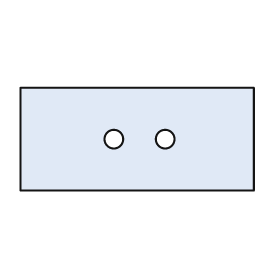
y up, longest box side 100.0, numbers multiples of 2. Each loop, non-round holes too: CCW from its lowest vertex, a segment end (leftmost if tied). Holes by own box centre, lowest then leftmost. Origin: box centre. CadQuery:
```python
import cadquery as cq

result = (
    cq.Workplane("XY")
    .moveTo(-50.0, -22.0)
    .lineTo(50.0, -22.0)
    .lineTo(50.0, 22.0)
    .lineTo(-50.0, 22.0)
    .close()
    .moveTo(-10.0, 0.0)
    .circle(4.0)
    .moveTo(12.0, 0.0)
    .circle(4.0)
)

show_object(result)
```